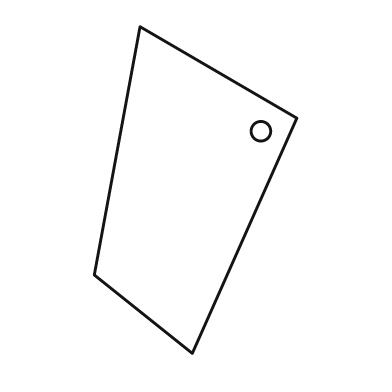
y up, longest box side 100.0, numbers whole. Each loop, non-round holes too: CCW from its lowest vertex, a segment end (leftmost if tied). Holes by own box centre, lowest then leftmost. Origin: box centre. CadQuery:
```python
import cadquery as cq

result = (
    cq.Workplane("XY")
    .moveTo(-1.0, -50.0)
    .lineTo(31.0, 22.0)
    .lineTo(-17.0, 50.0)
    .lineTo(-31.0, -26.0)
    .close()
    .moveTo(20.0, 18.0)
    .circle(3.0)
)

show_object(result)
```